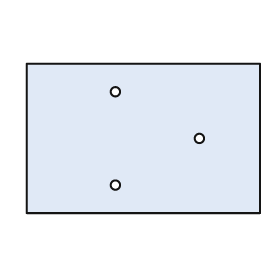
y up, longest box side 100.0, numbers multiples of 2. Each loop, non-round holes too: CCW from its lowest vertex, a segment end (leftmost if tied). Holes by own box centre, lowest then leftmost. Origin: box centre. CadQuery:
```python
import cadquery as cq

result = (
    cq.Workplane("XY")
    .moveTo(-50.0, -32.0)
    .lineTo(50.0, -32.0)
    .lineTo(50.0, 32.0)
    .lineTo(-50.0, 32.0)
    .close()
    .moveTo(-12.0, -20.0)
    .circle(2.0)
    .moveTo(24.0, 0.0)
    .circle(2.0)
    .moveTo(-12.0, 20.0)
    .circle(2.0)
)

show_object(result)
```